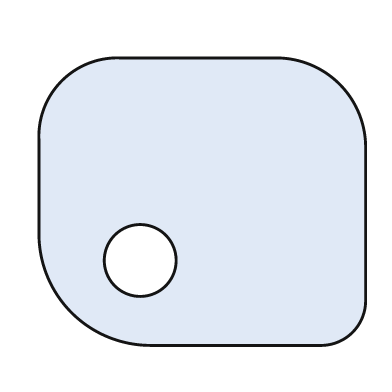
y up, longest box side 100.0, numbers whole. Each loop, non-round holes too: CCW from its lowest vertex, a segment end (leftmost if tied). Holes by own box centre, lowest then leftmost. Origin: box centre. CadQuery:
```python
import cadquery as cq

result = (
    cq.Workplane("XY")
    .moveTo(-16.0, -44.0)
    .lineTo(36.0, -44.0)
    .threePointArc((46.0, -40.0), (50.0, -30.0))
    .lineTo(50.0, 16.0)
    .threePointArc((42.0, 36.0), (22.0, 44.0))
    .lineTo(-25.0, 44.0)
    .threePointArc((-43.0, 37.0), (-50.0, 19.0))
    .lineTo(-50.0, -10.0)
    .threePointArc((-40.0, -34.0), (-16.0, -44.0))
    .close()
    .moveTo(-19.0, -18.0)
    .circle(11.0)
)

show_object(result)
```